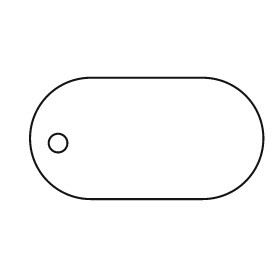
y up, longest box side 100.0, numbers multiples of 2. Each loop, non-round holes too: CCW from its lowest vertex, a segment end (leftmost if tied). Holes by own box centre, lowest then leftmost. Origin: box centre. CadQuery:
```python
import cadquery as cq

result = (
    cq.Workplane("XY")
    .moveTo(-24.0, -26.0)
    .lineTo(24.0, -26.0)
    .threePointArc((50.0, 0.0), (24.0, 26.0))
    .lineTo(-24.0, 26.0)
    .threePointArc((-50.0, 0.0), (-24.0, -26.0))
    .close()
    .moveTo(-38.0, -2.0)
    .circle(4.0)
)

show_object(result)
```